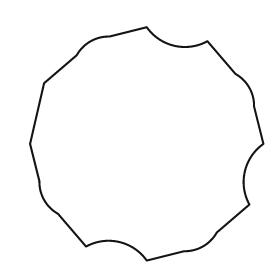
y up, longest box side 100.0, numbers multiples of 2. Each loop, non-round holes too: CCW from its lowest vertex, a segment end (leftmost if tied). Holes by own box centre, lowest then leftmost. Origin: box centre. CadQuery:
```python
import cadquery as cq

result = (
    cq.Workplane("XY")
    .moveTo(0.0, -50.0)
    .lineTo(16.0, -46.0)
    .threePointArc((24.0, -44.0), (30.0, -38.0))
    .lineTo(44.0, -26.0)
    .threePointArc((42.0, -12.0), (50.0, 0.0))
    .lineTo(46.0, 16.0)
    .threePointArc((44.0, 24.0), (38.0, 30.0))
    .lineTo(26.0, 44.0)
    .threePointArc((12.0, 42.0), (0.0, 50.0))
    .lineTo(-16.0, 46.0)
    .threePointArc((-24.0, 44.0), (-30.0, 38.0))
    .lineTo(-44.0, 26.0)
    .lineTo(-50.0, 0.0)
    .lineTo(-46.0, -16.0)
    .threePointArc((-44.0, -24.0), (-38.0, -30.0))
    .lineTo(-26.0, -44.0)
    .threePointArc((-12.0, -42.0), (0.0, -50.0))
    .close()
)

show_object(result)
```